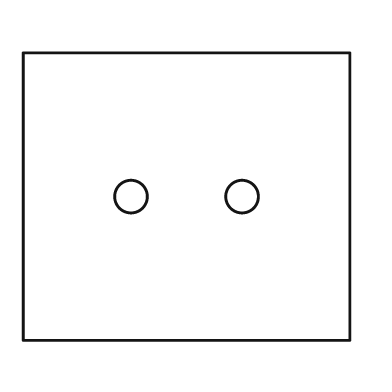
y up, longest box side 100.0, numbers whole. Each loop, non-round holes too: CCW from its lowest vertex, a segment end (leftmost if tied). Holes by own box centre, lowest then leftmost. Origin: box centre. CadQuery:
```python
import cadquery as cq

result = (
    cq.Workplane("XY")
    .moveTo(-50.0, -44.0)
    .lineTo(50.0, -44.0)
    .lineTo(50.0, 44.0)
    .lineTo(-50.0, 44.0)
    .close()
    .moveTo(-17.0, 0.0)
    .circle(5.0)
    .moveTo(17.0, 0.0)
    .circle(5.0)
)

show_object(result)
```